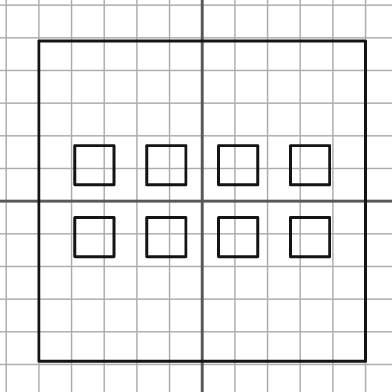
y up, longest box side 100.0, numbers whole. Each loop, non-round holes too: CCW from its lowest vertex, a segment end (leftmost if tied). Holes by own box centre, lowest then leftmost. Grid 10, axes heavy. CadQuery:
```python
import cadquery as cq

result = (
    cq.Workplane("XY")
    .moveTo(-50.0, -49.0)
    .lineTo(50.0, -49.0)
    .lineTo(50.0, 49.0)
    .lineTo(-50.0, 49.0)
    .close()
    .moveTo(-39.0, -17.0)
    .lineTo(-27.0, -17.0)
    .lineTo(-27.0, -5.0)
    .lineTo(-39.0, -5.0)
    .close()
    .moveTo(-17.0, -17.0)
    .lineTo(-5.0, -17.0)
    .lineTo(-5.0, -5.0)
    .lineTo(-17.0, -5.0)
    .close()
    .moveTo(5.0, -17.0)
    .lineTo(17.0, -17.0)
    .lineTo(17.0, -5.0)
    .lineTo(5.0, -5.0)
    .close()
    .moveTo(27.0, -17.0)
    .lineTo(39.0, -17.0)
    .lineTo(39.0, -5.0)
    .lineTo(27.0, -5.0)
    .close()
    .moveTo(-39.0, 5.0)
    .lineTo(-27.0, 5.0)
    .lineTo(-27.0, 17.0)
    .lineTo(-39.0, 17.0)
    .close()
    .moveTo(-17.0, 5.0)
    .lineTo(-5.0, 5.0)
    .lineTo(-5.0, 17.0)
    .lineTo(-17.0, 17.0)
    .close()
    .moveTo(5.0, 5.0)
    .lineTo(17.0, 5.0)
    .lineTo(17.0, 17.0)
    .lineTo(5.0, 17.0)
    .close()
    .moveTo(27.0, 5.0)
    .lineTo(39.0, 5.0)
    .lineTo(39.0, 17.0)
    .lineTo(27.0, 17.0)
    .close()
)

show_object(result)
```